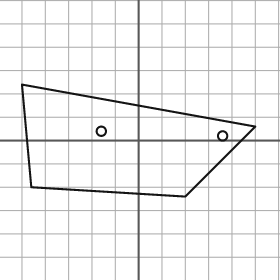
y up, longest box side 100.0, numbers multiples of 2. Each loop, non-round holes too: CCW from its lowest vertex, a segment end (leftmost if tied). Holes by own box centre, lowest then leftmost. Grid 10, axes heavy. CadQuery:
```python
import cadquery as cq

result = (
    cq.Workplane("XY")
    .moveTo(20.0, -24.0)
    .lineTo(50.0, 6.0)
    .lineTo(-50.0, 24.0)
    .lineTo(-46.0, -20.0)
    .close()
    .moveTo(36.0, 2.0)
    .circle(2.0)
    .moveTo(-16.0, 4.0)
    .circle(2.0)
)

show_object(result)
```